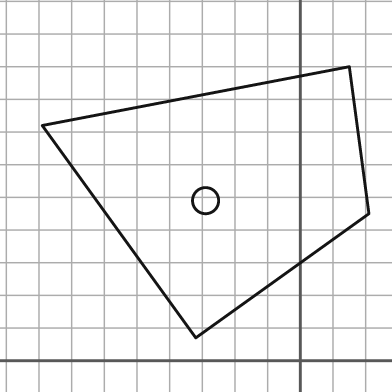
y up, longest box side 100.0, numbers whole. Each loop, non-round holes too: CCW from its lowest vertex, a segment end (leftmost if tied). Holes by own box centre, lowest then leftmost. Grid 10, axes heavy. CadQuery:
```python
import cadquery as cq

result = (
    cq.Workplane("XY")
    .moveTo(-32.0, 7.0)
    .lineTo(21.0, 45.0)
    .lineTo(15.0, 90.0)
    .lineTo(-79.0, 72.0)
    .close()
    .moveTo(-29.0, 49.0)
    .circle(4.0)
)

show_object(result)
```